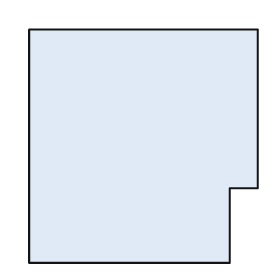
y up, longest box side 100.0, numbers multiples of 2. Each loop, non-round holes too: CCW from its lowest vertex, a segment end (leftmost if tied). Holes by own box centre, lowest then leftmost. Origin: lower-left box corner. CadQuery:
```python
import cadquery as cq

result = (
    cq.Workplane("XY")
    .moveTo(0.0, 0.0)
    .lineTo(86.0, 0.0)
    .lineTo(86.0, 32.0)
    .lineTo(98.0, 32.0)
    .lineTo(98.0, 100.0)
    .lineTo(0.0, 100.0)
    .close()
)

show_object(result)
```